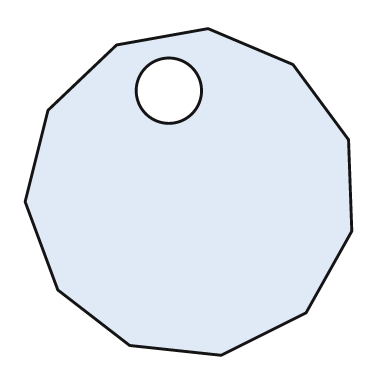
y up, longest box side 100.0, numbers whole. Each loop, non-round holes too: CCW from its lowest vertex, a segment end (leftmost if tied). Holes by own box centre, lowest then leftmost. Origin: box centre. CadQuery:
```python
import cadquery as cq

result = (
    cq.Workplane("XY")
    .moveTo(10.0, -50.0)
    .lineTo(36.0, -37.0)
    .lineTo(50.0, -12.0)
    .lineTo(49.0, 16.0)
    .lineTo(32.0, 39.0)
    .lineTo(6.0, 50.0)
    .lineTo(-22.0, 45.0)
    .lineTo(-43.0, 25.0)
    .lineTo(-50.0, -3.0)
    .lineTo(-40.0, -30.0)
    .lineTo(-18.0, -47.0)
    .close()
    .moveTo(-6.0, 31.0)
    .circle(10.0)
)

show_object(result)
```